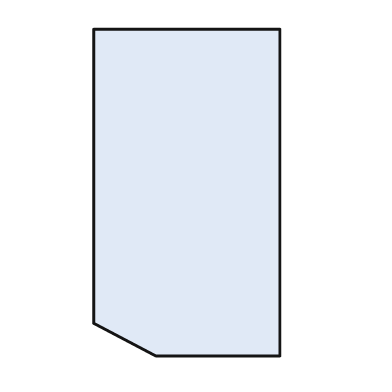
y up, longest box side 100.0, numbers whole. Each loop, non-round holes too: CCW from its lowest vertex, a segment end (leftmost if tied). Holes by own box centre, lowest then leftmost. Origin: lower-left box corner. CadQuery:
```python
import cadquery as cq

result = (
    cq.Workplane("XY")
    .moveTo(19.0, 0.0)
    .lineTo(57.0, 0.0)
    .lineTo(57.0, 100.0)
    .lineTo(0.0, 100.0)
    .lineTo(0.0, 10.0)
    .close()
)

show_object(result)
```